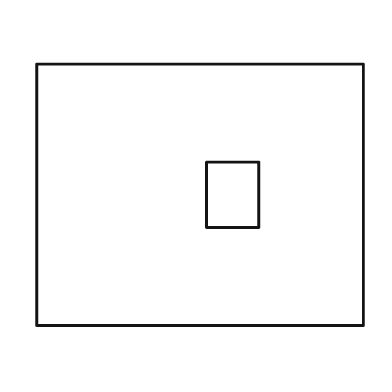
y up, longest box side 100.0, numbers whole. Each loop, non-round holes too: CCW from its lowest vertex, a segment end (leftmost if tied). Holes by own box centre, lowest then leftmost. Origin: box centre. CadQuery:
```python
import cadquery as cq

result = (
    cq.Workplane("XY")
    .moveTo(-50.0, -40.0)
    .lineTo(50.0, -40.0)
    .lineTo(50.0, 40.0)
    .lineTo(-50.0, 40.0)
    .close()
    .moveTo(2.0, -10.0)
    .lineTo(18.0, -10.0)
    .lineTo(18.0, 10.0)
    .lineTo(2.0, 10.0)
    .close()
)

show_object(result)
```